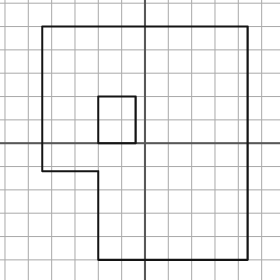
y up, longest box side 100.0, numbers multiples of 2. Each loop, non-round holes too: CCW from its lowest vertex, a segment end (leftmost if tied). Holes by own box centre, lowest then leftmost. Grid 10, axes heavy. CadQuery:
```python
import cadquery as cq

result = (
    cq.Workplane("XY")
    .moveTo(-20.0, -50.0)
    .lineTo(44.0, -50.0)
    .lineTo(44.0, 50.0)
    .lineTo(-44.0, 50.0)
    .lineTo(-44.0, -12.0)
    .lineTo(-20.0, -12.0)
    .close()
    .moveTo(-20.0, 0.0)
    .lineTo(-4.0, 0.0)
    .lineTo(-4.0, 20.0)
    .lineTo(-20.0, 20.0)
    .close()
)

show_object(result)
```